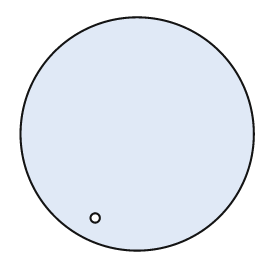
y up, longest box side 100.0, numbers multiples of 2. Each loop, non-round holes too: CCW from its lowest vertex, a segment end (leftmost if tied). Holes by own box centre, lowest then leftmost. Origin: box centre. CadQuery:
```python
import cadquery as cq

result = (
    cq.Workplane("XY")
    .moveTo(0.0, 0.0)
    .circle(50.0)
    .moveTo(-18.0, -36.0)
    .circle(2.0)
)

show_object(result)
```